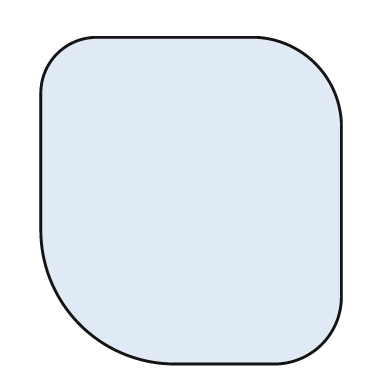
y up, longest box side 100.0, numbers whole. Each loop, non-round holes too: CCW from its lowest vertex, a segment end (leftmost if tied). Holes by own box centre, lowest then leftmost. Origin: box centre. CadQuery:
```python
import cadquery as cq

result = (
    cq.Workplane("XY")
    .moveTo(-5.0, -50.0)
    .lineTo(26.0, -50.0)
    .threePointArc((40.0, -44.0), (46.0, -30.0))
    .lineTo(46.0, 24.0)
    .threePointArc((38.0, 42.0), (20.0, 50.0))
    .lineTo(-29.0, 50.0)
    .threePointArc((-41.0, 45.0), (-46.0, 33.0))
    .lineTo(-46.0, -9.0)
    .threePointArc((-34.0, -38.0), (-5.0, -50.0))
    .close()
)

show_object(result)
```